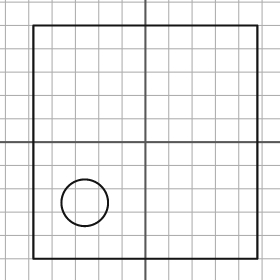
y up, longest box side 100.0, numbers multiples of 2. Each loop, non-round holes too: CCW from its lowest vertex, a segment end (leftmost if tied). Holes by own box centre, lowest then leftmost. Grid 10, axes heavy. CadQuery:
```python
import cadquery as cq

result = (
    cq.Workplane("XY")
    .moveTo(-48.0, -50.0)
    .lineTo(48.0, -50.0)
    .lineTo(48.0, 50.0)
    .lineTo(-48.0, 50.0)
    .close()
    .moveTo(-26.0, -26.0)
    .circle(10.0)
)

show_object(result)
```